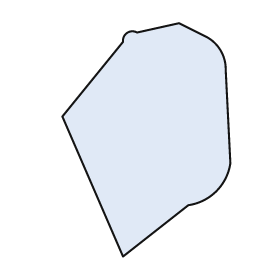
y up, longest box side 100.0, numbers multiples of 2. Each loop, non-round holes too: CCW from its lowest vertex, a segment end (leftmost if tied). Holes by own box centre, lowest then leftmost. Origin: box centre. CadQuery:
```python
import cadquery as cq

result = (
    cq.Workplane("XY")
    .moveTo(-10.0, -50.0)
    .lineTo(18.0, -28.0)
    .threePointArc((30.0, -22.0), (36.0, -10.0))
    .lineTo(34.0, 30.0)
    .threePointArc((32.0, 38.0), (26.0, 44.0))
    .lineTo(14.0, 50.0)
    .lineTo(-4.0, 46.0)
    .threePointArc((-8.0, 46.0), (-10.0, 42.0))
    .lineTo(-36.0, 10.0)
    .close()
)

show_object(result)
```